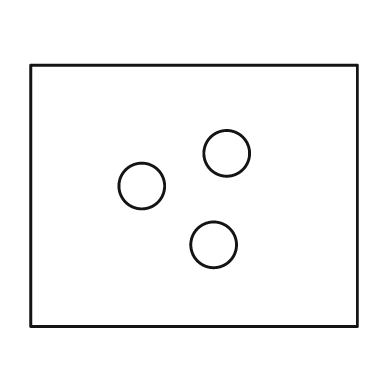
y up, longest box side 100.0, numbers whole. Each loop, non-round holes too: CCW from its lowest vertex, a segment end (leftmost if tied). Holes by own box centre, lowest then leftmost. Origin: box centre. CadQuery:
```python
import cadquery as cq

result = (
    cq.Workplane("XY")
    .moveTo(-50.0, -40.0)
    .lineTo(50.0, -40.0)
    .lineTo(50.0, 40.0)
    .lineTo(-50.0, 40.0)
    .close()
    .moveTo(6.0, -15.0)
    .circle(7.0)
    .moveTo(-16.0, 3.0)
    .circle(7.0)
    .moveTo(10.0, 13.0)
    .circle(7.0)
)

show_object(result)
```